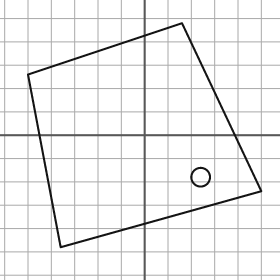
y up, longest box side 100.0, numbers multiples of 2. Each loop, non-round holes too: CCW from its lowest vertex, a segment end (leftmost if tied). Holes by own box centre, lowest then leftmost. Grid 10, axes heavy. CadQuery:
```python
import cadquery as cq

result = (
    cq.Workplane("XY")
    .moveTo(-36.0, -48.0)
    .lineTo(50.0, -24.0)
    .lineTo(16.0, 48.0)
    .lineTo(-50.0, 26.0)
    .close()
    .moveTo(24.0, -18.0)
    .circle(4.0)
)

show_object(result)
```